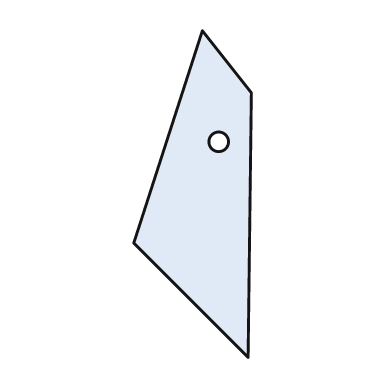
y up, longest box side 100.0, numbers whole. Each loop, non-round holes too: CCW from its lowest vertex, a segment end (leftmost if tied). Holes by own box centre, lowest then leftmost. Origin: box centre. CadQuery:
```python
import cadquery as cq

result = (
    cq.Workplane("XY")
    .moveTo(17.0, -50.0)
    .lineTo(18.0, 31.0)
    .lineTo(3.0, 50.0)
    .lineTo(-18.0, -15.0)
    .close()
    .moveTo(8.0, 16.0)
    .circle(3.0)
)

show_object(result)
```